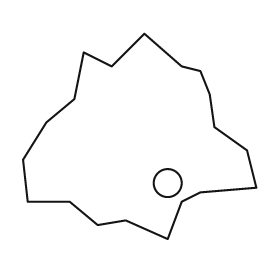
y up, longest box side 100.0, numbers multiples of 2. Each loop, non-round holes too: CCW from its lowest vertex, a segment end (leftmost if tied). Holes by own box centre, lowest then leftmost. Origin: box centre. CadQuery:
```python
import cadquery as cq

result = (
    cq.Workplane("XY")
    .moveTo(12.0, -44.0)
    .lineTo(18.0, -28.0)
    .lineTo(26.0, -24.0)
    .lineTo(50.0, -22.0)
    .lineTo(46.0, -6.0)
    .lineTo(32.0, 4.0)
    .lineTo(30.0, 18.0)
    .lineTo(26.0, 28.0)
    .lineTo(18.0, 30.0)
    .lineTo(2.0, 44.0)
    .lineTo(-12.0, 30.0)
    .lineTo(-24.0, 36.0)
    .lineTo(-28.0, 16.0)
    .lineTo(-40.0, 6.0)
    .lineTo(-50.0, -10.0)
    .lineTo(-48.0, -28.0)
    .lineTo(-30.0, -28.0)
    .lineTo(-18.0, -38.0)
    .lineTo(-6.0, -36.0)
    .close()
    .moveTo(12.0, -20.0)
    .circle(6.0)
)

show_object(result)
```